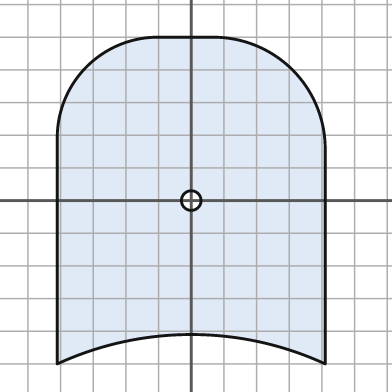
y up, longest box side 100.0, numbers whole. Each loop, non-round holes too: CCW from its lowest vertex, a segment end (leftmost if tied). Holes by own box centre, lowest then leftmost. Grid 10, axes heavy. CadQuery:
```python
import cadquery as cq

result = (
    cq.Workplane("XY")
    .moveTo(-41.0, -50.0)
    .threePointArc((0.0, -41.0), (41.0, -50.0))
    .lineTo(41.0, 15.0)
    .threePointArc((31.0, 40.0), (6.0, 50.0))
    .lineTo(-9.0, 50.0)
    .threePointArc((-32.0, 41.0), (-41.0, 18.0))
    .close()
    .moveTo(0.0, 0.0)
    .circle(3.0)
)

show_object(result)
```